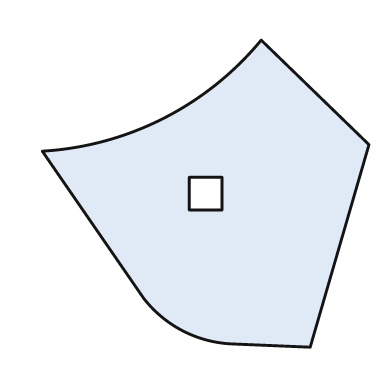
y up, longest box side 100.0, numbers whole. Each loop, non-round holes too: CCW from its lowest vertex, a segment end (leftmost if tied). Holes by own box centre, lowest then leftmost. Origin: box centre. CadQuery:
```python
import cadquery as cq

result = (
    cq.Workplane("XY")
    .moveTo(32.0, -47.0)
    .lineTo(50.0, 15.0)
    .lineTo(17.0, 47.0)
    .threePointArc((-13.0, 23.0), (-50.0, 13.0))
    .lineTo(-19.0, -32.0)
    .threePointArc((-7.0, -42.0), (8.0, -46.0))
    .close()
    .moveTo(-5.0, -5.0)
    .lineTo(5.0, -5.0)
    .lineTo(5.0, 5.0)
    .lineTo(-5.0, 5.0)
    .close()
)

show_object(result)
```